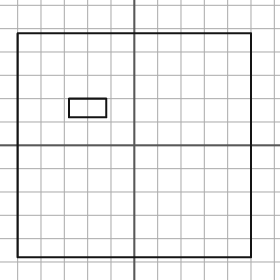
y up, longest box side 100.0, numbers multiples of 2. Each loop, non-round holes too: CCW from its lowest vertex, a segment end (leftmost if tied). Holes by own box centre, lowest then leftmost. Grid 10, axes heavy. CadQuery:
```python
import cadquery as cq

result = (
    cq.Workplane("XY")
    .moveTo(-50.0, -48.0)
    .lineTo(50.0, -48.0)
    .lineTo(50.0, 48.0)
    .lineTo(-50.0, 48.0)
    .close()
    .moveTo(-28.0, 12.0)
    .lineTo(-12.0, 12.0)
    .lineTo(-12.0, 20.0)
    .lineTo(-28.0, 20.0)
    .close()
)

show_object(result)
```